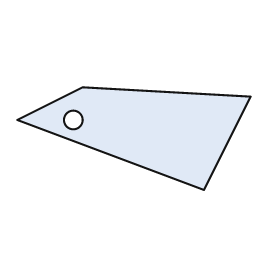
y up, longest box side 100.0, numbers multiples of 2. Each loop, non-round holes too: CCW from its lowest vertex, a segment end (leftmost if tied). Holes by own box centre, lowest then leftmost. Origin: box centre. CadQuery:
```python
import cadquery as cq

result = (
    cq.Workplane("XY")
    .moveTo(30.0, -22.0)
    .lineTo(50.0, 18.0)
    .lineTo(-22.0, 22.0)
    .lineTo(-50.0, 8.0)
    .close()
    .moveTo(-26.0, 8.0)
    .circle(4.0)
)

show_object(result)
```